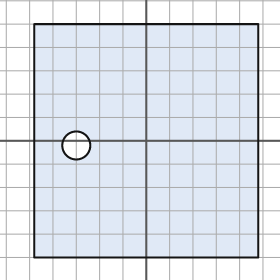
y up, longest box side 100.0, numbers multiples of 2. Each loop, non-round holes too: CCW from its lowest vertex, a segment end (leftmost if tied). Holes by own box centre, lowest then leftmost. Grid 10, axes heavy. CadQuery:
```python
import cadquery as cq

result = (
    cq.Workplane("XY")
    .moveTo(-48.0, -50.0)
    .lineTo(48.0, -50.0)
    .lineTo(48.0, 50.0)
    .lineTo(-48.0, 50.0)
    .close()
    .moveTo(-30.0, -2.0)
    .circle(6.0)
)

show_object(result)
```